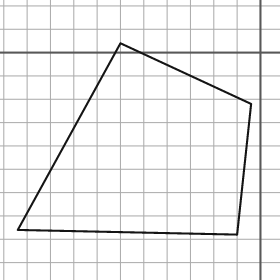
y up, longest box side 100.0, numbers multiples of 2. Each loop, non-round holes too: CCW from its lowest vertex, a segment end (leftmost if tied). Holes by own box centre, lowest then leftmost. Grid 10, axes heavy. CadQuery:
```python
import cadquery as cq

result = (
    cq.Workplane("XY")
    .moveTo(-10.0, -78.0)
    .lineTo(-4.0, -22.0)
    .lineTo(-60.0, 4.0)
    .lineTo(-104.0, -76.0)
    .close()
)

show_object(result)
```